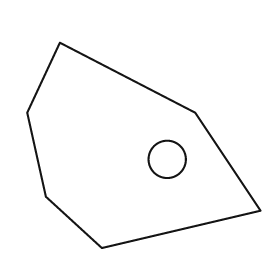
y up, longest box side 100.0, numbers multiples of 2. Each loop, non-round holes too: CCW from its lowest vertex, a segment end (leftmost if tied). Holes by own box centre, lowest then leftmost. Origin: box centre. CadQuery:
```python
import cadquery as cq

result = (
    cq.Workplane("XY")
    .moveTo(-18.0, -44.0)
    .lineTo(50.0, -28.0)
    .lineTo(22.0, 14.0)
    .lineTo(-36.0, 44.0)
    .lineTo(-50.0, 14.0)
    .lineTo(-42.0, -22.0)
    .close()
    .moveTo(10.0, -6.0)
    .circle(8.0)
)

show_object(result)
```